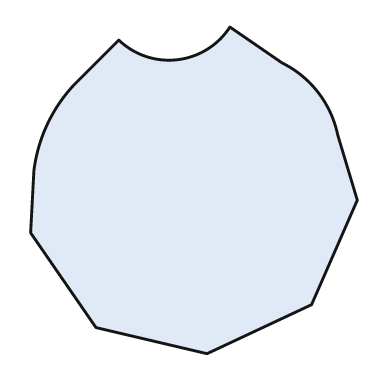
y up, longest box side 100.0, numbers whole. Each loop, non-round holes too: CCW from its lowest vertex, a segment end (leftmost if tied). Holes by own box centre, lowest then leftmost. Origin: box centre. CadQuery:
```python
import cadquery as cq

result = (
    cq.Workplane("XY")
    .moveTo(4.0, -50.0)
    .lineTo(36.0, -35.0)
    .lineTo(50.0, -3.0)
    .lineTo(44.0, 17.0)
    .threePointArc((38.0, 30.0), (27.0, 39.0))
    .lineTo(11.0, 50.0)
    .threePointArc((-5.0, 40.0), (-23.0, 46.0))
    .lineTo(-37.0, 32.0)
    .threePointArc((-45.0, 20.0), (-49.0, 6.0))
    .lineTo(-50.0, -13.0)
    .lineTo(-30.0, -42.0)
    .close()
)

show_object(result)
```